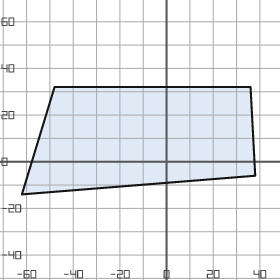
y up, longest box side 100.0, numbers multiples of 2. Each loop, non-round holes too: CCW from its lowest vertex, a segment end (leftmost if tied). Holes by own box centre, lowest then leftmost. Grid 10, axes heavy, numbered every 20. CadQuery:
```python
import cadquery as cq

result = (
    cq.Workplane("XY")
    .moveTo(-62.0, -14.0)
    .lineTo(38.0, -6.0)
    .lineTo(36.0, 32.0)
    .lineTo(-48.0, 32.0)
    .close()
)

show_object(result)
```